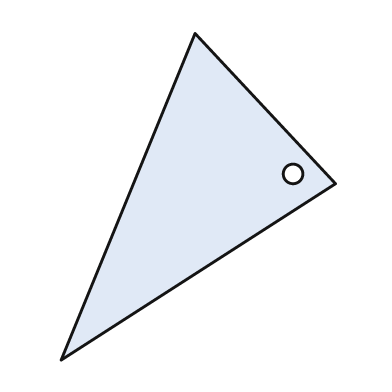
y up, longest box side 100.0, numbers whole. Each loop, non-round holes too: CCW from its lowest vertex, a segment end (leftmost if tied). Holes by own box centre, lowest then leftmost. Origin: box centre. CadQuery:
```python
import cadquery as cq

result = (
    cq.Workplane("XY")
    .moveTo(-42.0, -50.0)
    .lineTo(42.0, 4.0)
    .lineTo(-1.0, 50.0)
    .close()
    .moveTo(29.0, 7.0)
    .circle(3.0)
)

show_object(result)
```